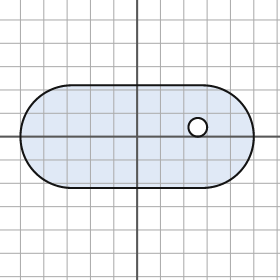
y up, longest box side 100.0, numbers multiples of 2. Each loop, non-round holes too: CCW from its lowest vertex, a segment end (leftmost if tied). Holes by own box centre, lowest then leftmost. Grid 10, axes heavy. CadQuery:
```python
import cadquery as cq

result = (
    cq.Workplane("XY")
    .moveTo(-28.0, -22.0)
    .lineTo(28.0, -22.0)
    .threePointArc((50.0, 0.0), (28.0, 22.0))
    .lineTo(-28.0, 22.0)
    .threePointArc((-50.0, 0.0), (-28.0, -22.0))
    .close()
    .moveTo(26.0, 4.0)
    .circle(4.0)
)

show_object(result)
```